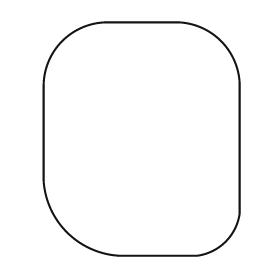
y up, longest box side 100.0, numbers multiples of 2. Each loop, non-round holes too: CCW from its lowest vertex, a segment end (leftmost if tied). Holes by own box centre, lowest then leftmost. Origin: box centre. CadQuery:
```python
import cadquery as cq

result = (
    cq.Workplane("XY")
    .moveTo(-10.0, -50.0)
    .lineTo(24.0, -50.0)
    .threePointArc((36.0, -44.0), (42.0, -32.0))
    .lineTo(42.0, 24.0)
    .threePointArc((34.0, 42.0), (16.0, 50.0))
    .lineTo(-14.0, 50.0)
    .threePointArc((-34.0, 42.0), (-42.0, 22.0))
    .lineTo(-42.0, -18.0)
    .threePointArc((-32.0, -40.0), (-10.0, -50.0))
    .close()
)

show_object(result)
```